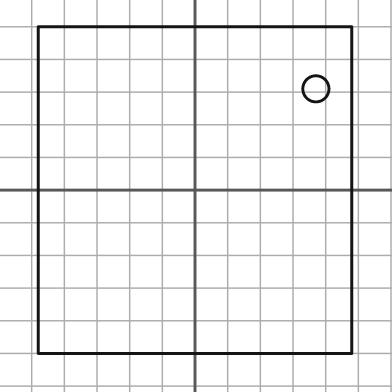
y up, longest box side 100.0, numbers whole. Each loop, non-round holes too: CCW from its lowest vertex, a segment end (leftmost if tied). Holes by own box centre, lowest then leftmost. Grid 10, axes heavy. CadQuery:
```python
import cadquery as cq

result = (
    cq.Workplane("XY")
    .moveTo(-48.0, -50.0)
    .lineTo(48.0, -50.0)
    .lineTo(48.0, 50.0)
    .lineTo(-48.0, 50.0)
    .close()
    .moveTo(37.0, 31.0)
    .circle(4.0)
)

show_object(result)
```